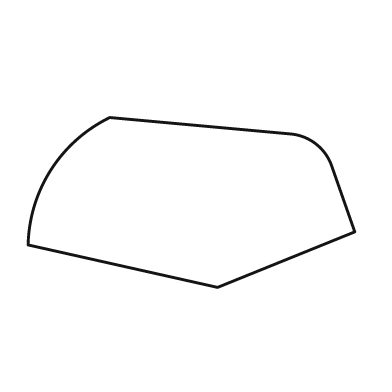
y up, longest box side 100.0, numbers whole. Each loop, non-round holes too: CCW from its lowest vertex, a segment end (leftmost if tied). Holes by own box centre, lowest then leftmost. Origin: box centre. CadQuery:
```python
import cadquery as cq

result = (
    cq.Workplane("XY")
    .moveTo(8.0, -26.0)
    .lineTo(50.0, -9.0)
    .lineTo(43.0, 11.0)
    .threePointArc((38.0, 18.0), (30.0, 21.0))
    .lineTo(-25.0, 26.0)
    .threePointArc((-43.0, 10.0), (-50.0, -13.0))
    .close()
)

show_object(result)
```